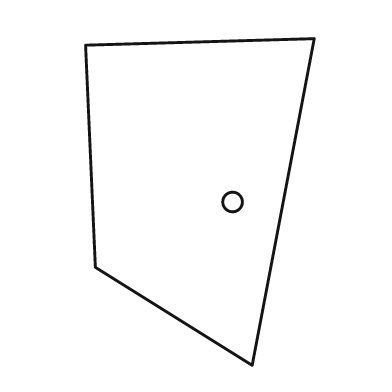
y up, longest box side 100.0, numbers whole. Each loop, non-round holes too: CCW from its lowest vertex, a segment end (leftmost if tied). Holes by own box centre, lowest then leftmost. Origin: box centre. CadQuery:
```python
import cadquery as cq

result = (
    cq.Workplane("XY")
    .moveTo(16.0, -50.0)
    .lineTo(35.0, 50.0)
    .lineTo(-35.0, 48.0)
    .lineTo(-32.0, -20.0)
    .close()
    .moveTo(10.0, 0.0)
    .circle(3.0)
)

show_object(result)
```